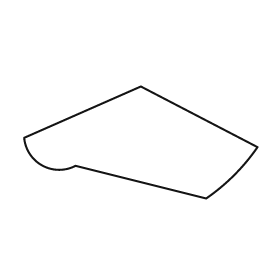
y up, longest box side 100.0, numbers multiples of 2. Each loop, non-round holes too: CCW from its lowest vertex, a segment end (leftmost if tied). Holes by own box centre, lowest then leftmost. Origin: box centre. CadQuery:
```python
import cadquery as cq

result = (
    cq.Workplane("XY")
    .moveTo(28.0, -24.0)
    .threePointArc((40.0, -14.0), (50.0, -2.0))
    .lineTo(0.0, 24.0)
    .lineTo(-50.0, 2.0)
    .threePointArc((-42.0, -10.0), (-28.0, -10.0))
    .close()
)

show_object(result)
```